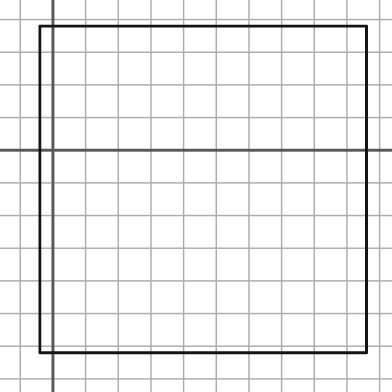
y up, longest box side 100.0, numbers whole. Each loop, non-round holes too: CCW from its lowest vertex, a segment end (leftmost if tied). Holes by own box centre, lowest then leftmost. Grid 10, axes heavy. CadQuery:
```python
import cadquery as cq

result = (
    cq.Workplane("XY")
    .moveTo(-4.0, -62.0)
    .lineTo(96.0, -62.0)
    .lineTo(96.0, 38.0)
    .lineTo(-4.0, 38.0)
    .close()
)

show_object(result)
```